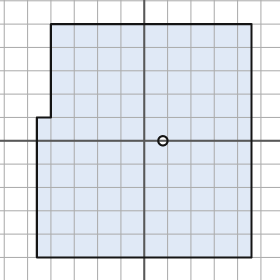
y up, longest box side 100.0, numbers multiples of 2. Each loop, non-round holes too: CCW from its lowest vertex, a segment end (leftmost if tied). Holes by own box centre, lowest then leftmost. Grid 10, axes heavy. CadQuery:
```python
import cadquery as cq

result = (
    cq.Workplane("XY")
    .moveTo(-46.0, -50.0)
    .lineTo(46.0, -50.0)
    .lineTo(46.0, 50.0)
    .lineTo(-40.0, 50.0)
    .lineTo(-40.0, 10.0)
    .lineTo(-46.0, 10.0)
    .close()
    .moveTo(8.0, 0.0)
    .circle(2.0)
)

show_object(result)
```